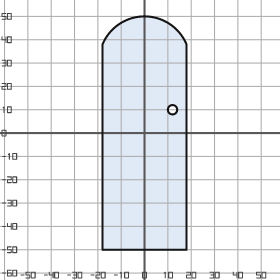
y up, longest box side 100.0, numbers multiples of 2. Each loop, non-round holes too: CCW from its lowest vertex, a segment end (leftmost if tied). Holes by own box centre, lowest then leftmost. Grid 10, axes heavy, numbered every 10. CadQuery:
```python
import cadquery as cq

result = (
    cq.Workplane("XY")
    .moveTo(-18.0, -50.0)
    .lineTo(18.0, -50.0)
    .lineTo(18.0, 38.0)
    .threePointArc((0.0, 50.0), (-18.0, 38.0))
    .close()
    .moveTo(12.0, 10.0)
    .circle(2.0)
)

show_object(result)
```